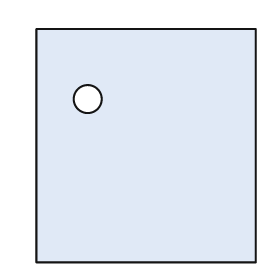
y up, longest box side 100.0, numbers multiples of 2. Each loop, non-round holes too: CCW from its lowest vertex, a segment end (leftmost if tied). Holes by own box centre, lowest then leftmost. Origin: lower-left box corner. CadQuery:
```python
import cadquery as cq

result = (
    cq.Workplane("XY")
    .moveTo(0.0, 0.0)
    .lineTo(94.0, 0.0)
    .lineTo(94.0, 100.0)
    .lineTo(0.0, 100.0)
    .close()
    .moveTo(22.0, 70.0)
    .circle(6.0)
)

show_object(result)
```